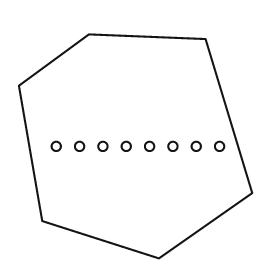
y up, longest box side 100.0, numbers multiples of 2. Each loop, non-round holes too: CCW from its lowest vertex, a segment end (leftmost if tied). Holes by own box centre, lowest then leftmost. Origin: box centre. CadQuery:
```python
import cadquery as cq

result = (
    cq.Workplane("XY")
    .moveTo(10.0, -48.0)
    .lineTo(50.0, -20.0)
    .lineTo(30.0, 46.0)
    .lineTo(-20.0, 48.0)
    .lineTo(-50.0, 26.0)
    .lineTo(-40.0, -32.0)
    .close()
    .moveTo(-34.0, 0.0)
    .circle(2.0)
    .moveTo(-24.0, 0.0)
    .circle(2.0)
    .moveTo(-14.0, 0.0)
    .circle(2.0)
    .moveTo(-4.0, 0.0)
    .circle(2.0)
    .moveTo(6.0, 0.0)
    .circle(2.0)
    .moveTo(16.0, 0.0)
    .circle(2.0)
    .moveTo(26.0, 0.0)
    .circle(2.0)
    .moveTo(36.0, 0.0)
    .circle(2.0)
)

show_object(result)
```